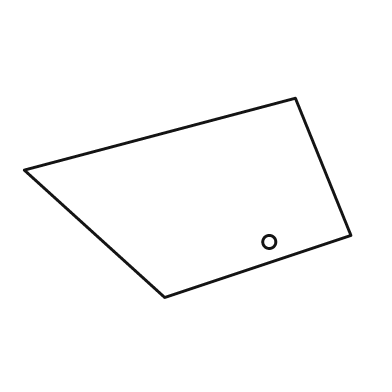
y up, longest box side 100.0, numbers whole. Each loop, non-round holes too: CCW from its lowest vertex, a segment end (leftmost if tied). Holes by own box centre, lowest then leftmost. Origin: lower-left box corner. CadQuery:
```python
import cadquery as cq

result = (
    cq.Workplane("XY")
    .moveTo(43.0, 0.0)
    .lineTo(100.0, 19.0)
    .lineTo(83.0, 61.0)
    .lineTo(0.0, 39.0)
    .close()
    .moveTo(75.0, 17.0)
    .circle(2.0)
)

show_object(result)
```